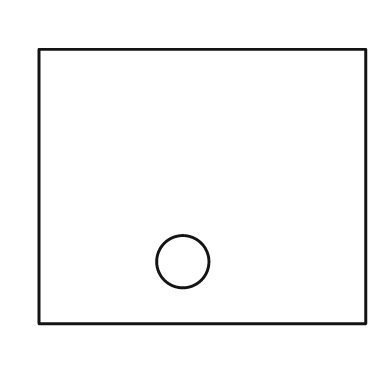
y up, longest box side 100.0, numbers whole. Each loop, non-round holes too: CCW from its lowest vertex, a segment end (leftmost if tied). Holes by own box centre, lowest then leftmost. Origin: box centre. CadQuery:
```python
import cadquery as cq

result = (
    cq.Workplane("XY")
    .moveTo(-50.0, -42.0)
    .lineTo(50.0, -42.0)
    .lineTo(50.0, 42.0)
    .lineTo(-50.0, 42.0)
    .close()
    .moveTo(-6.0, -23.0)
    .circle(8.0)
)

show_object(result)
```